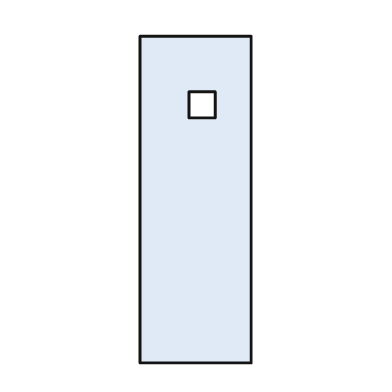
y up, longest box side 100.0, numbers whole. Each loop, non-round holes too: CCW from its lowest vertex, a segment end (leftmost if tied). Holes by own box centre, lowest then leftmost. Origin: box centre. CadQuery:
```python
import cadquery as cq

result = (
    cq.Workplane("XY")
    .moveTo(-17.0, -50.0)
    .lineTo(17.0, -50.0)
    .lineTo(17.0, 50.0)
    .lineTo(-17.0, 50.0)
    .close()
    .moveTo(-2.0, 25.0)
    .lineTo(6.0, 25.0)
    .lineTo(6.0, 33.0)
    .lineTo(-2.0, 33.0)
    .close()
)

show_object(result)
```